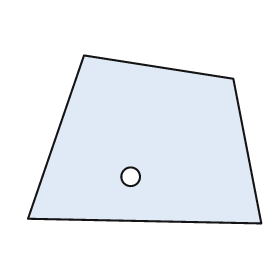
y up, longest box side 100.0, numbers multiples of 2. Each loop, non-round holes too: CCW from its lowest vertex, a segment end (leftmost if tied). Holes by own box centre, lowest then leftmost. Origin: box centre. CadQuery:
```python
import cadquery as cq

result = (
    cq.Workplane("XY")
    .moveTo(50.0, -36.0)
    .lineTo(38.0, 26.0)
    .lineTo(-26.0, 36.0)
    .lineTo(-50.0, -34.0)
    .close()
    .moveTo(-6.0, -16.0)
    .circle(4.0)
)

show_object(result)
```